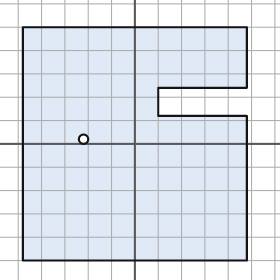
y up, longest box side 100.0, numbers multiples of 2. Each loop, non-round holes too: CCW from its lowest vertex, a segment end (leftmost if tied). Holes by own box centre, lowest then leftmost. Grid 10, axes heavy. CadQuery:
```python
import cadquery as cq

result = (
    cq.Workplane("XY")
    .moveTo(-48.0, -50.0)
    .lineTo(48.0, -50.0)
    .lineTo(48.0, 12.0)
    .lineTo(10.0, 12.0)
    .lineTo(10.0, 24.0)
    .lineTo(48.0, 24.0)
    .lineTo(48.0, 50.0)
    .lineTo(-48.0, 50.0)
    .close()
    .moveTo(-22.0, 2.0)
    .circle(2.0)
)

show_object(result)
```